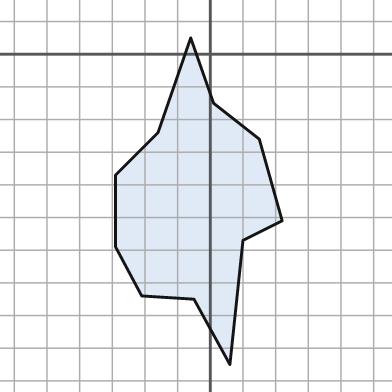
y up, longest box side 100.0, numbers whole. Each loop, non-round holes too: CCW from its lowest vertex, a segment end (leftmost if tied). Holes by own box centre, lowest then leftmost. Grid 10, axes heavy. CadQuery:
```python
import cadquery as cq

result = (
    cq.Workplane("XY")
    .moveTo(6.0, -95.0)
    .lineTo(10.0, -57.0)
    .lineTo(22.0, -51.0)
    .lineTo(15.0, -26.0)
    .lineTo(1.0, -15.0)
    .lineTo(-6.0, 5.0)
    .lineTo(-16.0, -24.0)
    .lineTo(-29.0, -37.0)
    .lineTo(-29.0, -59.0)
    .lineTo(-21.0, -74.0)
    .lineTo(-5.0, -75.0)
    .close()
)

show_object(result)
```